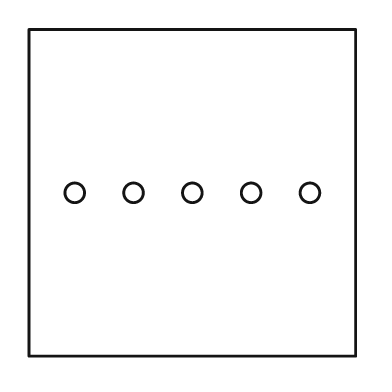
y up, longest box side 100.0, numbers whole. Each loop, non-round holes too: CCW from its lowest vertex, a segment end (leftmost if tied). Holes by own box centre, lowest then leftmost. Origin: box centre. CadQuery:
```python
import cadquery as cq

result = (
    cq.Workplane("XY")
    .moveTo(-50.0, -50.0)
    .lineTo(50.0, -50.0)
    .lineTo(50.0, 50.0)
    .lineTo(-50.0, 50.0)
    .close()
    .moveTo(-36.0, 0.0)
    .circle(3.0)
    .moveTo(-18.0, 0.0)
    .circle(3.0)
    .moveTo(0.0, 0.0)
    .circle(3.0)
    .moveTo(18.0, 0.0)
    .circle(3.0)
    .moveTo(36.0, 0.0)
    .circle(3.0)
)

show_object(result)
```